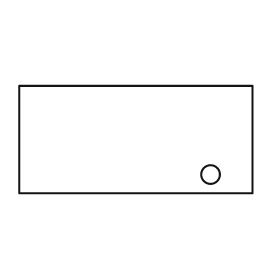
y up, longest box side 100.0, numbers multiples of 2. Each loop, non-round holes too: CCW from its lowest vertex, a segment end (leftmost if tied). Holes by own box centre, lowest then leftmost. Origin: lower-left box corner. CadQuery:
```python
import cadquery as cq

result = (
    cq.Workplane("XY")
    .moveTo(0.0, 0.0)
    .lineTo(100.0, 0.0)
    .lineTo(100.0, 46.0)
    .lineTo(0.0, 46.0)
    .close()
    .moveTo(82.0, 8.0)
    .circle(4.0)
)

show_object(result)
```